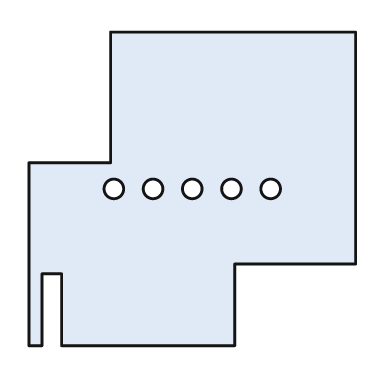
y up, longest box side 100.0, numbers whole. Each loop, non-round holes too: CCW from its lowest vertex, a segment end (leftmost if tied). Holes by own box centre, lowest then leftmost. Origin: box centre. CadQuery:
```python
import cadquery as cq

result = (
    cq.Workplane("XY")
    .moveTo(-50.0, -48.0)
    .lineTo(-46.0, -48.0)
    .lineTo(-46.0, -26.0)
    .lineTo(-40.0, -26.0)
    .lineTo(-40.0, -48.0)
    .lineTo(13.0, -48.0)
    .lineTo(13.0, -23.0)
    .lineTo(50.0, -23.0)
    .lineTo(50.0, 48.0)
    .lineTo(-25.0, 48.0)
    .lineTo(-25.0, 8.0)
    .lineTo(-50.0, 8.0)
    .close()
    .moveTo(-24.0, 0.0)
    .circle(3.0)
    .moveTo(-12.0, 0.0)
    .circle(3.0)
    .moveTo(0.0, 0.0)
    .circle(3.0)
    .moveTo(12.0, 0.0)
    .circle(3.0)
    .moveTo(24.0, 0.0)
    .circle(3.0)
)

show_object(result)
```